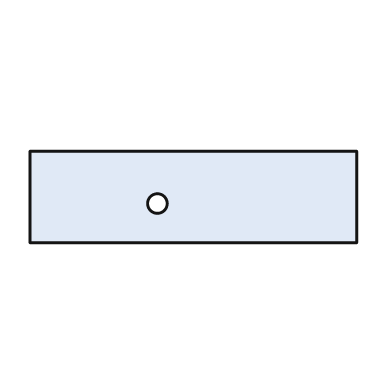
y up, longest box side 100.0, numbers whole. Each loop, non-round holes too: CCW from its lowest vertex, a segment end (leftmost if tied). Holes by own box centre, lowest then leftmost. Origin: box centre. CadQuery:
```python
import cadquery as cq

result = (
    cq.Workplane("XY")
    .moveTo(-50.0, -14.0)
    .lineTo(50.0, -14.0)
    .lineTo(50.0, 14.0)
    .lineTo(-50.0, 14.0)
    .close()
    .moveTo(-11.0, -2.0)
    .circle(3.0)
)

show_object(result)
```